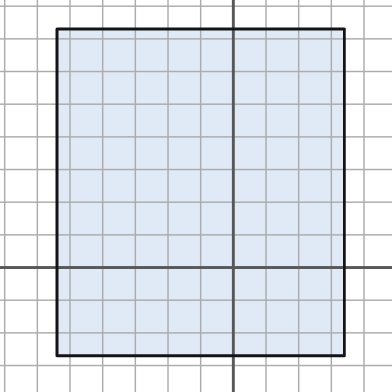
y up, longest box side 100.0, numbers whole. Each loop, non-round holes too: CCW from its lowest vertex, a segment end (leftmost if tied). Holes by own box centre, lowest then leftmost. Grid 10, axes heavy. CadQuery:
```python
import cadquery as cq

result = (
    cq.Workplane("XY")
    .moveTo(-54.0, -27.0)
    .lineTo(34.0, -27.0)
    .lineTo(34.0, 73.0)
    .lineTo(-54.0, 73.0)
    .close()
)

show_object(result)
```